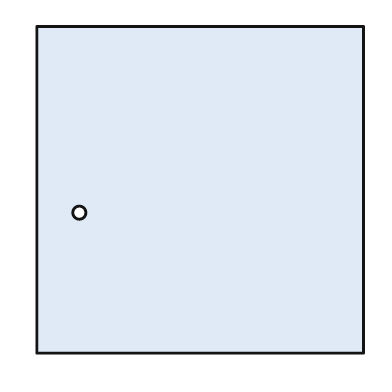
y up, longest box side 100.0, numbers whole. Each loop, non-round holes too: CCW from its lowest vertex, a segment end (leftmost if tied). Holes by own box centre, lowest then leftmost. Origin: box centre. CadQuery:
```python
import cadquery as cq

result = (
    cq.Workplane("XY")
    .moveTo(-50.0, -50.0)
    .lineTo(50.0, -50.0)
    .lineTo(50.0, 50.0)
    .lineTo(-50.0, 50.0)
    .close()
    .moveTo(-37.0, -7.0)
    .circle(2.0)
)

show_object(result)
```